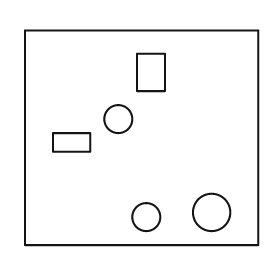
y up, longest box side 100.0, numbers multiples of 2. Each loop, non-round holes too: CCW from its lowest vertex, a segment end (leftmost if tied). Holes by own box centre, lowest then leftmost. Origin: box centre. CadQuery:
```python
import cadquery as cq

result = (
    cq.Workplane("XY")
    .moveTo(-50.0, -46.0)
    .lineTo(50.0, -46.0)
    .lineTo(50.0, 46.0)
    .lineTo(-50.0, 46.0)
    .close()
    .moveTo(2.0, -34.0)
    .circle(6.0)
    .moveTo(30.0, -32.0)
    .circle(8.0)
    .moveTo(-38.0, -6.0)
    .lineTo(-22.0, -6.0)
    .lineTo(-22.0, 2.0)
    .lineTo(-38.0, 2.0)
    .close()
    .moveTo(-10.0, 8.0)
    .circle(6.0)
    .moveTo(-2.0, 20.0)
    .lineTo(10.0, 20.0)
    .lineTo(10.0, 36.0)
    .lineTo(-2.0, 36.0)
    .close()
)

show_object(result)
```